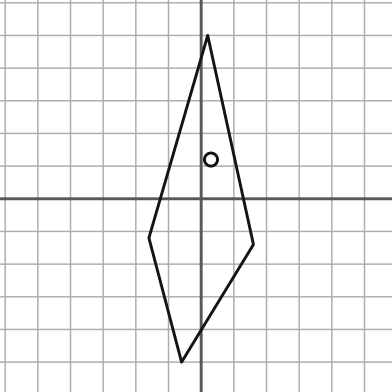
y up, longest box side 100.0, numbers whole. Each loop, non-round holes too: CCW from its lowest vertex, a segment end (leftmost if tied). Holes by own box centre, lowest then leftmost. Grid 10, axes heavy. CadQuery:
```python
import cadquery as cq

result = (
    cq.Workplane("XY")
    .moveTo(-6.0, -50.0)
    .lineTo(16.0, -14.0)
    .lineTo(2.0, 50.0)
    .lineTo(-16.0, -12.0)
    .close()
    .moveTo(3.0, 12.0)
    .circle(2.0)
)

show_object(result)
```